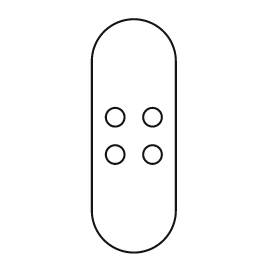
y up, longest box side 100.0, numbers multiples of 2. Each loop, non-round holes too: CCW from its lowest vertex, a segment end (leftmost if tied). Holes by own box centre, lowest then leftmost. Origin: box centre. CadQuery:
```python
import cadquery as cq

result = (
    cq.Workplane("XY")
    .moveTo(-18.0, -32.0)
    .threePointArc((0.0, -50.0), (18.0, -32.0))
    .lineTo(18.0, 32.0)
    .threePointArc((0.0, 50.0), (-18.0, 32.0))
    .close()
    .moveTo(-8.0, -8.0)
    .circle(4.0)
    .moveTo(8.0, -8.0)
    .circle(4.0)
    .moveTo(-8.0, 8.0)
    .circle(4.0)
    .moveTo(8.0, 8.0)
    .circle(4.0)
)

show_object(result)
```